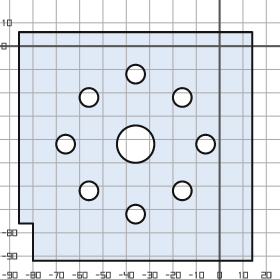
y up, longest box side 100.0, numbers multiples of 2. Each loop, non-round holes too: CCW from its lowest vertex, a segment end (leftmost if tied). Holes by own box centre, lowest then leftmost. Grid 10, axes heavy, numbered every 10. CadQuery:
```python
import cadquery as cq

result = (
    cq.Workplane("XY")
    .moveTo(-80.0, -92.0)
    .lineTo(14.0, -92.0)
    .lineTo(14.0, 6.0)
    .lineTo(-86.0, 6.0)
    .lineTo(-86.0, -76.0)
    .lineTo(-80.0, -76.0)
    .close()
    .moveTo(-36.0, -72.0)
    .circle(4.0)
    .moveTo(-56.0, -62.0)
    .circle(4.0)
    .moveTo(-16.0, -62.0)
    .circle(4.0)
    .moveTo(-66.0, -42.0)
    .circle(4.0)
    .moveTo(-36.0, -42.0)
    .circle(8.0)
    .moveTo(-6.0, -42.0)
    .circle(4.0)
    .moveTo(-56.0, -22.0)
    .circle(4.0)
    .moveTo(-16.0, -22.0)
    .circle(4.0)
    .moveTo(-36.0, -12.0)
    .circle(4.0)
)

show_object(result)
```